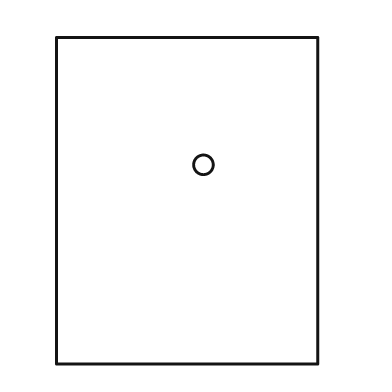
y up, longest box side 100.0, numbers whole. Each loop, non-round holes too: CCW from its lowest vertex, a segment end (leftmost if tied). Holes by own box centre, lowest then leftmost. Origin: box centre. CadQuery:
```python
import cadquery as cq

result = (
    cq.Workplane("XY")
    .moveTo(-40.0, -50.0)
    .lineTo(40.0, -50.0)
    .lineTo(40.0, 50.0)
    .lineTo(-40.0, 50.0)
    .close()
    .moveTo(5.0, 11.0)
    .circle(3.0)
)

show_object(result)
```